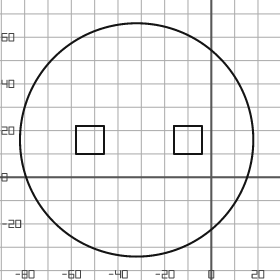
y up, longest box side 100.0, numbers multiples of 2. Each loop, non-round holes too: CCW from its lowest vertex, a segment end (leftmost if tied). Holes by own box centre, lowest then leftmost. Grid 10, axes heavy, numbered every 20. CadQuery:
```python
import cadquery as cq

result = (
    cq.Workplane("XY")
    .moveTo(-32.0, 16.0)
    .circle(50.0)
    .moveTo(-58.0, 10.0)
    .lineTo(-46.0, 10.0)
    .lineTo(-46.0, 22.0)
    .lineTo(-58.0, 22.0)
    .close()
    .moveTo(-16.0, 10.0)
    .lineTo(-4.0, 10.0)
    .lineTo(-4.0, 22.0)
    .lineTo(-16.0, 22.0)
    .close()
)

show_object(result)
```